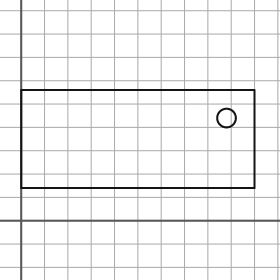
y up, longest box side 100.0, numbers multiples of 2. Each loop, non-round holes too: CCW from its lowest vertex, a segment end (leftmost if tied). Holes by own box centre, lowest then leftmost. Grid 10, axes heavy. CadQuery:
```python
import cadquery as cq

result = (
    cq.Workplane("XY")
    .moveTo(0.0, 14.0)
    .lineTo(100.0, 14.0)
    .lineTo(100.0, 56.0)
    .lineTo(0.0, 56.0)
    .close()
    .moveTo(88.0, 44.0)
    .circle(4.0)
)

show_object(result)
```